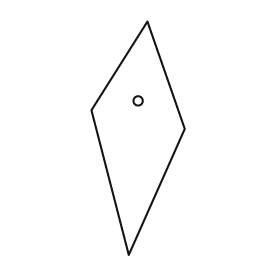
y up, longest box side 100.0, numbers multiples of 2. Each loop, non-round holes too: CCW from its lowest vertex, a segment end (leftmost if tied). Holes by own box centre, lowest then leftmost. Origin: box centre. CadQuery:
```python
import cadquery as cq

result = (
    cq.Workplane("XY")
    .moveTo(-4.0, -50.0)
    .lineTo(20.0, 4.0)
    .lineTo(4.0, 50.0)
    .lineTo(-20.0, 12.0)
    .close()
    .moveTo(0.0, 16.0)
    .circle(2.0)
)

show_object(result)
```